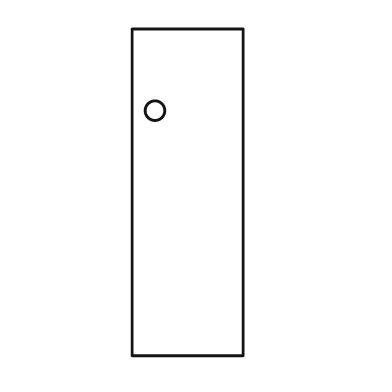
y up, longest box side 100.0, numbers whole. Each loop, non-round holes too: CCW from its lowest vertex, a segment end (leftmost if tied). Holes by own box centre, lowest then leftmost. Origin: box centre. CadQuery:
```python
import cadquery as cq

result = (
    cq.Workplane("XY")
    .moveTo(-17.0, -50.0)
    .lineTo(17.0, -50.0)
    .lineTo(17.0, 50.0)
    .lineTo(-17.0, 50.0)
    .close()
    .moveTo(-10.0, 25.0)
    .circle(3.0)
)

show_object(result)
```